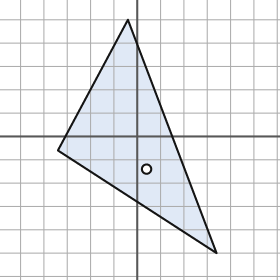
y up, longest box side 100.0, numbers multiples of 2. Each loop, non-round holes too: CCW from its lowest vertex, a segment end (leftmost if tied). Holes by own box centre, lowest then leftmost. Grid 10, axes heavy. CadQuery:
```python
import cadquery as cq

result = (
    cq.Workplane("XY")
    .moveTo(34.0, -50.0)
    .lineTo(-4.0, 50.0)
    .lineTo(-34.0, -6.0)
    .close()
    .moveTo(4.0, -14.0)
    .circle(2.0)
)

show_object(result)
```